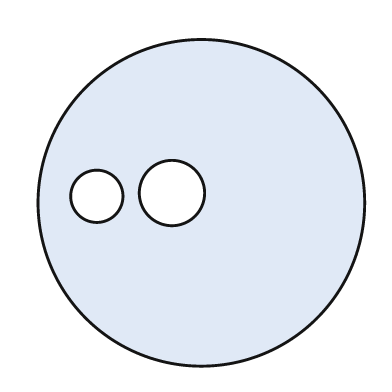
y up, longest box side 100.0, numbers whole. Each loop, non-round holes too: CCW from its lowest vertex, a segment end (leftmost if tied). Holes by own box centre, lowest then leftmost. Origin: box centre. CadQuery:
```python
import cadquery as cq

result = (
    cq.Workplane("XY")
    .moveTo(0.0, 0.0)
    .circle(50.0)
    .moveTo(-32.0, 2.0)
    .circle(8.0)
    .moveTo(-9.0, 3.0)
    .circle(10.0)
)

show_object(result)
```